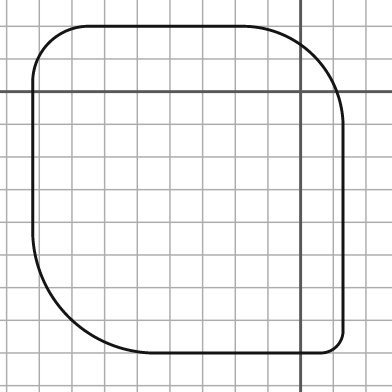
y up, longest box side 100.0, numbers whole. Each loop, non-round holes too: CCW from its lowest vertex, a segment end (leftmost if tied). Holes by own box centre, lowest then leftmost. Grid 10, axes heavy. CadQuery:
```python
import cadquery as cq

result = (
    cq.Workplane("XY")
    .moveTo(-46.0, -80.0)
    .lineTo(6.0, -80.0)
    .threePointArc((11.0, -78.0), (13.0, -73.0))
    .lineTo(13.0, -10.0)
    .threePointArc((4.0, 11.0), (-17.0, 20.0))
    .lineTo(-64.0, 20.0)
    .threePointArc((-77.0, 15.0), (-82.0, 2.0))
    .lineTo(-82.0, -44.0)
    .threePointArc((-71.0, -69.0), (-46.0, -80.0))
    .close()
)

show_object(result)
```